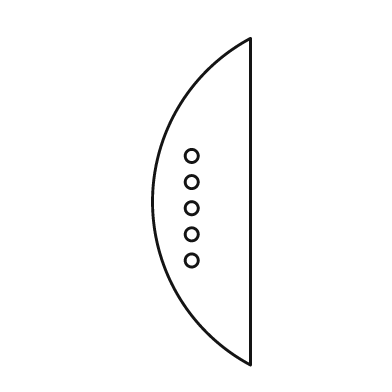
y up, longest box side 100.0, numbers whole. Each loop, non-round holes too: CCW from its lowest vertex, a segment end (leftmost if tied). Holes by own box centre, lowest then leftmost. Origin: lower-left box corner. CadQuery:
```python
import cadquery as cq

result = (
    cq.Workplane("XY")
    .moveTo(30.0, 0.0)
    .lineTo(30.0, 100.0)
    .threePointArc((0.0, 50.0), (30.0, 0.0))
    .close()
    .moveTo(12.0, 32.0)
    .circle(2.0)
    .moveTo(12.0, 40.0)
    .circle(2.0)
    .moveTo(12.0, 48.0)
    .circle(2.0)
    .moveTo(12.0, 56.0)
    .circle(2.0)
    .moveTo(12.0, 64.0)
    .circle(2.0)
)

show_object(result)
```